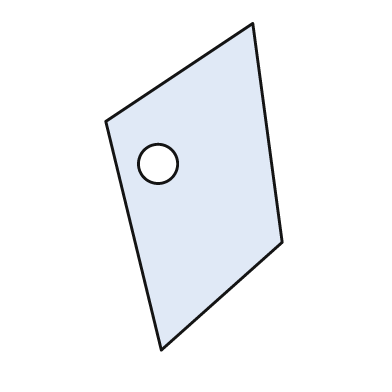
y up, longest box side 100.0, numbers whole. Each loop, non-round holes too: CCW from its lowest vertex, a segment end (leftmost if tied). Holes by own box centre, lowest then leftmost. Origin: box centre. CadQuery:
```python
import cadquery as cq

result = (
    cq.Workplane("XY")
    .moveTo(-10.0, -50.0)
    .lineTo(27.0, -17.0)
    .lineTo(18.0, 50.0)
    .lineTo(-27.0, 20.0)
    .close()
    .moveTo(-11.0, 7.0)
    .circle(6.0)
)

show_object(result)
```